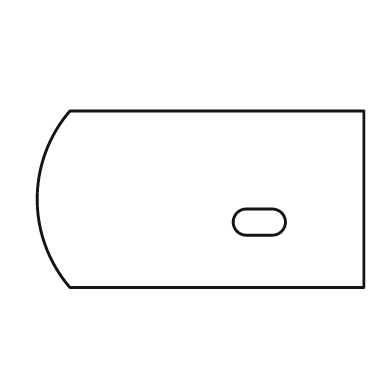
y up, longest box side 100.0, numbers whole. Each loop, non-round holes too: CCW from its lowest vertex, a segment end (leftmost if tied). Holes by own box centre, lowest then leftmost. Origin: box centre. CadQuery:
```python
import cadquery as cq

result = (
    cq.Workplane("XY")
    .moveTo(-40.0, -27.0)
    .lineTo(50.0, -27.0)
    .lineTo(50.0, 27.0)
    .lineTo(-40.0, 27.0)
    .threePointArc((-50.0, 0.0), (-40.0, -27.0))
    .close()
    .moveTo(14.0, -11.0)
    .lineTo(22.0, -11.0)
    .threePointArc((26.0, -7.0), (22.0, -3.0))
    .lineTo(14.0, -3.0)
    .threePointArc((10.0, -7.0), (14.0, -11.0))
    .close()
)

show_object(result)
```